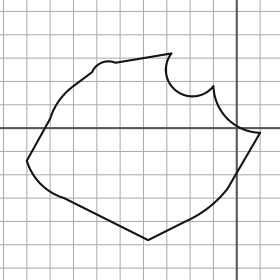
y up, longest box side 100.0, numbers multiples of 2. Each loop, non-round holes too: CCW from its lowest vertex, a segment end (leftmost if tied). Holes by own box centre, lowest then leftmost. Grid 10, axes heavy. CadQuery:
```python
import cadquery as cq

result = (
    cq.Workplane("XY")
    .moveTo(-38.0, -48.0)
    .lineTo(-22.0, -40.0)
    .threePointArc((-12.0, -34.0), (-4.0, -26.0))
    .lineTo(10.0, -2.0)
    .threePointArc((-4.0, 4.0), (-10.0, 18.0))
    .threePointArc((-26.0, 16.0), (-28.0, 32.0))
    .lineTo(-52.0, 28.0)
    .threePointArc((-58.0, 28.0), (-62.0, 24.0))
    .lineTo(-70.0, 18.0)
    .threePointArc((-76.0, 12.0), (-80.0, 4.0))
    .lineTo(-90.0, -14.0)
    .threePointArc((-84.0, -24.0), (-74.0, -30.0))
    .close()
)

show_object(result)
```